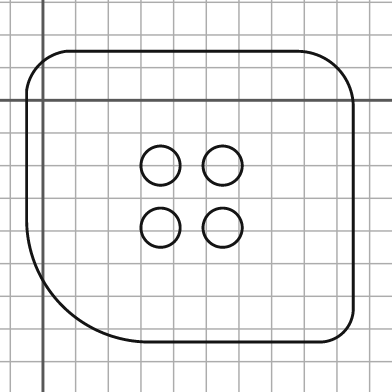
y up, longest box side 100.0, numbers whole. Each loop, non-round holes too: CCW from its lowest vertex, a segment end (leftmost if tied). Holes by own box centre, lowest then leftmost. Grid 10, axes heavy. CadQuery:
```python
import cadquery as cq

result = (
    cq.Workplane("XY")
    .moveTo(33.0, -74.0)
    .lineTo(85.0, -74.0)
    .threePointArc((92.0, -71.0), (95.0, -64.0))
    .lineTo(95.0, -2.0)
    .threePointArc((90.0, 10.0), (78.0, 15.0))
    .lineTo(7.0, 15.0)
    .threePointArc((-1.0, 11.0), (-5.0, 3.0))
    .lineTo(-5.0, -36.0)
    .threePointArc((6.0, -63.0), (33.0, -74.0))
    .close()
    .moveTo(36.0, -39.0)
    .circle(6.0)
    .moveTo(55.0, -39.0)
    .circle(6.0)
    .moveTo(36.0, -20.0)
    .circle(6.0)
    .moveTo(55.0, -20.0)
    .circle(6.0)
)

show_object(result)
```